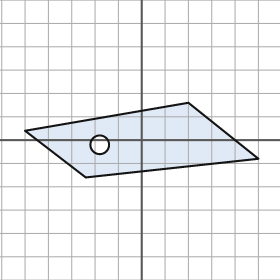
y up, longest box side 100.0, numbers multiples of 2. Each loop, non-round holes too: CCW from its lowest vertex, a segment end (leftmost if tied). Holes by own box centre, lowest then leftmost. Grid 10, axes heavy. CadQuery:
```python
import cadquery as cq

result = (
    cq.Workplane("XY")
    .moveTo(-24.0, -16.0)
    .lineTo(50.0, -8.0)
    .lineTo(20.0, 16.0)
    .lineTo(-50.0, 4.0)
    .close()
    .moveTo(-18.0, -2.0)
    .circle(4.0)
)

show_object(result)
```